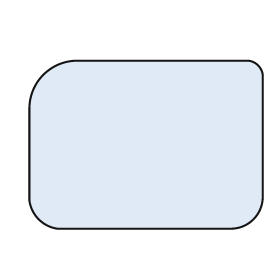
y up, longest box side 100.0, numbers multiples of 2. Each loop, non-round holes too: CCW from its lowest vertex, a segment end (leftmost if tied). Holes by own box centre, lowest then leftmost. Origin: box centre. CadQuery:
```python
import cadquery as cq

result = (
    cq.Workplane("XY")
    .moveTo(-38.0, -36.0)
    .lineTo(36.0, -36.0)
    .threePointArc((46.0, -32.0), (50.0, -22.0))
    .lineTo(50.0, 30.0)
    .threePointArc((48.0, 34.0), (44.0, 36.0))
    .lineTo(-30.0, 36.0)
    .threePointArc((-44.0, 30.0), (-50.0, 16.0))
    .lineTo(-50.0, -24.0)
    .threePointArc((-46.0, -32.0), (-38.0, -36.0))
    .close()
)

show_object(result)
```